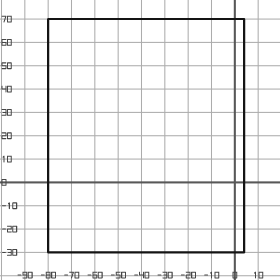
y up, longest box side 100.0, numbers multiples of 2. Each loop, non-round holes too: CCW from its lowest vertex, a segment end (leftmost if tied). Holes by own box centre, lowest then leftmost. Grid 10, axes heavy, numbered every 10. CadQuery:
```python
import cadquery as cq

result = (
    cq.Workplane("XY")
    .moveTo(-80.0, -30.0)
    .lineTo(4.0, -30.0)
    .lineTo(4.0, 70.0)
    .lineTo(-80.0, 70.0)
    .close()
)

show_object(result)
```